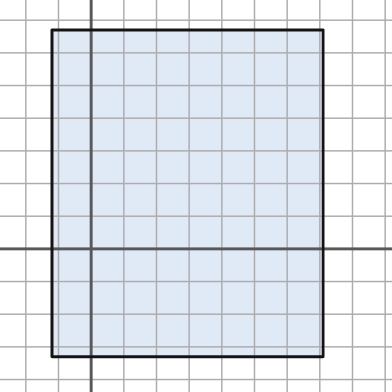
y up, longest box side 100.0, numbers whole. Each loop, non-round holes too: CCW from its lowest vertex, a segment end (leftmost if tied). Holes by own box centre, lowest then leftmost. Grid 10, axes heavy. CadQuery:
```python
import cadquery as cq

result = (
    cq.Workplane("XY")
    .moveTo(-12.0, -33.0)
    .lineTo(71.0, -33.0)
    .lineTo(71.0, 67.0)
    .lineTo(-12.0, 67.0)
    .close()
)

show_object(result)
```